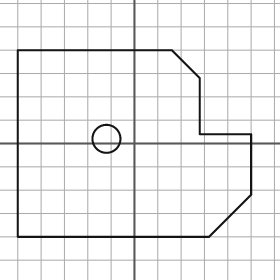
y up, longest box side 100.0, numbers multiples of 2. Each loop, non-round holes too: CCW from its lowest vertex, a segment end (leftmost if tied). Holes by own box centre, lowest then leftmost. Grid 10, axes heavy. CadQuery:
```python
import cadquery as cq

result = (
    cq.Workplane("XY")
    .moveTo(-50.0, -40.0)
    .lineTo(32.0, -40.0)
    .lineTo(50.0, -22.0)
    .lineTo(50.0, 4.0)
    .lineTo(28.0, 4.0)
    .lineTo(28.0, 28.0)
    .lineTo(16.0, 40.0)
    .lineTo(-50.0, 40.0)
    .close()
    .moveTo(-12.0, 2.0)
    .circle(6.0)
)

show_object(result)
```